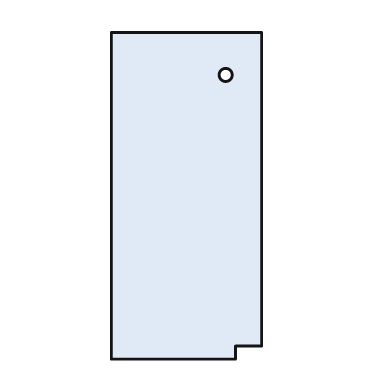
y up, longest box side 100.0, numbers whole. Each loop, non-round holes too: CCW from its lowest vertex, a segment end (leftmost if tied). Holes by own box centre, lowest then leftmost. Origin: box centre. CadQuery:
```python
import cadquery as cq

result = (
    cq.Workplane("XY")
    .moveTo(-23.0, -50.0)
    .lineTo(15.0, -50.0)
    .lineTo(15.0, -46.0)
    .lineTo(23.0, -46.0)
    .lineTo(23.0, 50.0)
    .lineTo(-23.0, 50.0)
    .close()
    .moveTo(12.0, 37.0)
    .circle(2.0)
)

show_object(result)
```